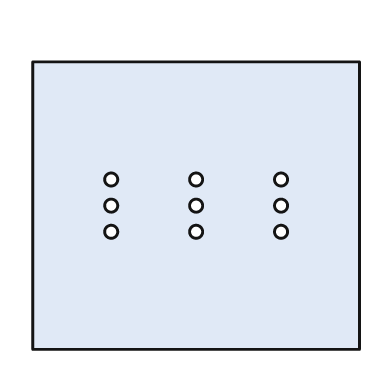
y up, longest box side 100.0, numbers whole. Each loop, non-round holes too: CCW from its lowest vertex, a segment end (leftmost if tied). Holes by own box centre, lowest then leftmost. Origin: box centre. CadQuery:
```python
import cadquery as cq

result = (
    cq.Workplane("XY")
    .moveTo(-50.0, -44.0)
    .lineTo(50.0, -44.0)
    .lineTo(50.0, 44.0)
    .lineTo(-50.0, 44.0)
    .close()
    .moveTo(-26.0, -8.0)
    .circle(2.0)
    .moveTo(0.0, -8.0)
    .circle(2.0)
    .moveTo(26.0, -8.0)
    .circle(2.0)
    .moveTo(-26.0, 0.0)
    .circle(2.0)
    .moveTo(0.0, 0.0)
    .circle(2.0)
    .moveTo(26.0, 0.0)
    .circle(2.0)
    .moveTo(-26.0, 8.0)
    .circle(2.0)
    .moveTo(0.0, 8.0)
    .circle(2.0)
    .moveTo(26.0, 8.0)
    .circle(2.0)
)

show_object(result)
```